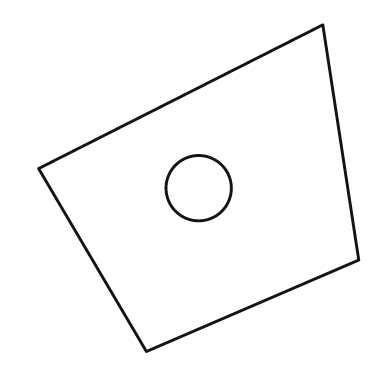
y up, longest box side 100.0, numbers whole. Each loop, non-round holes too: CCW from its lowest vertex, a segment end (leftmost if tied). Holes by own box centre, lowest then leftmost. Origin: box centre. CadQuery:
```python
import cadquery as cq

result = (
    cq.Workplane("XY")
    .moveTo(-16.0, -50.0)
    .lineTo(49.0, -22.0)
    .lineTo(38.0, 50.0)
    .lineTo(-49.0, 6.0)
    .close()
    .moveTo(0.0, 0.0)
    .circle(10.0)
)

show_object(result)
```